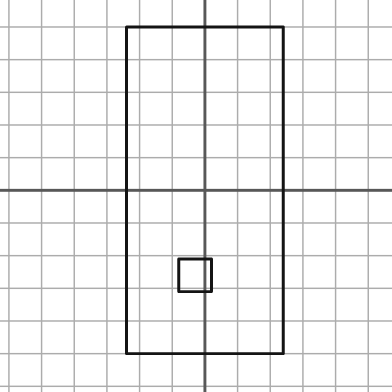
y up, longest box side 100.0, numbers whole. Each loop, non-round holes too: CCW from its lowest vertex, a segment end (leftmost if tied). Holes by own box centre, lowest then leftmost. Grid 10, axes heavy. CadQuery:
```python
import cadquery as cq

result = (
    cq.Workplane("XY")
    .moveTo(-24.0, -50.0)
    .lineTo(24.0, -50.0)
    .lineTo(24.0, 50.0)
    .lineTo(-24.0, 50.0)
    .close()
    .moveTo(-8.0, -31.0)
    .lineTo(2.0, -31.0)
    .lineTo(2.0, -21.0)
    .lineTo(-8.0, -21.0)
    .close()
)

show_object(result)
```